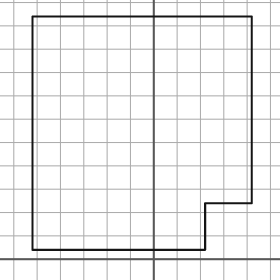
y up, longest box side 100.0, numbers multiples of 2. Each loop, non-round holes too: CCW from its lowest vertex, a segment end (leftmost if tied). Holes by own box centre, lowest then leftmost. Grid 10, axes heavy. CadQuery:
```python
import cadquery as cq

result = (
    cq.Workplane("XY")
    .moveTo(-52.0, 4.0)
    .lineTo(22.0, 4.0)
    .lineTo(22.0, 24.0)
    .lineTo(42.0, 24.0)
    .lineTo(42.0, 104.0)
    .lineTo(-52.0, 104.0)
    .close()
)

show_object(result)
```